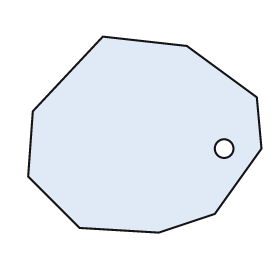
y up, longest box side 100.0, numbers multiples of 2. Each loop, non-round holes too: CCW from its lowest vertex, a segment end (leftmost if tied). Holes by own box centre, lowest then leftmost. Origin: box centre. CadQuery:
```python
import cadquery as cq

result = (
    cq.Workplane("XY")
    .moveTo(6.0, -42.0)
    .lineTo(30.0, -34.0)
    .lineTo(50.0, -6.0)
    .lineTo(48.0, 16.0)
    .lineTo(18.0, 38.0)
    .lineTo(-18.0, 42.0)
    .lineTo(-48.0, 10.0)
    .lineTo(-50.0, -18.0)
    .lineTo(-28.0, -40.0)
    .close()
    .moveTo(34.0, -6.0)
    .circle(4.0)
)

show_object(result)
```